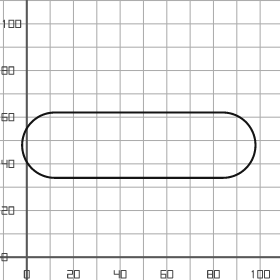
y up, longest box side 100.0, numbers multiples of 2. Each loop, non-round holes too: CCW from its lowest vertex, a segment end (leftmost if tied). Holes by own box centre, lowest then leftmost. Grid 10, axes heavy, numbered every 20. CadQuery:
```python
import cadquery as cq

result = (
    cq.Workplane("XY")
    .moveTo(12.0, 34.0)
    .lineTo(84.0, 34.0)
    .threePointArc((98.0, 48.0), (84.0, 62.0))
    .lineTo(12.0, 62.0)
    .threePointArc((-2.0, 48.0), (12.0, 34.0))
    .close()
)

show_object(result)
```